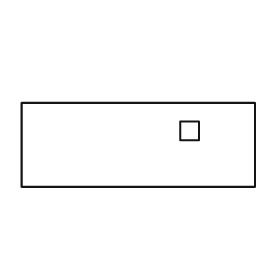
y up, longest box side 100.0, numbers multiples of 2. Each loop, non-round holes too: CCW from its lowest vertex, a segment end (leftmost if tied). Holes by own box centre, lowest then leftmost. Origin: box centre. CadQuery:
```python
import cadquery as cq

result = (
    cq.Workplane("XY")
    .moveTo(-50.0, -18.0)
    .lineTo(50.0, -18.0)
    .lineTo(50.0, 18.0)
    .lineTo(-50.0, 18.0)
    .close()
    .moveTo(18.0, 2.0)
    .lineTo(26.0, 2.0)
    .lineTo(26.0, 10.0)
    .lineTo(18.0, 10.0)
    .close()
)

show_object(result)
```